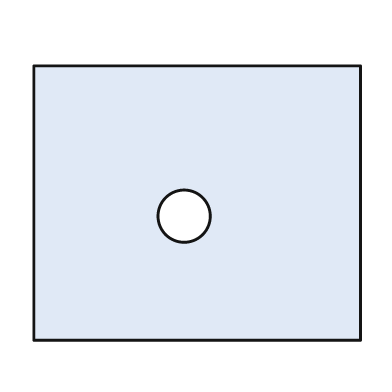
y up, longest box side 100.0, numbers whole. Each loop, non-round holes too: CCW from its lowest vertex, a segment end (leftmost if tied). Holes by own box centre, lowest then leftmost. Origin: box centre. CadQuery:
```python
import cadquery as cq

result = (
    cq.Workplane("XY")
    .moveTo(-50.0, -42.0)
    .lineTo(50.0, -42.0)
    .lineTo(50.0, 42.0)
    .lineTo(-50.0, 42.0)
    .close()
    .moveTo(-4.0, -4.0)
    .circle(8.0)
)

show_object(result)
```